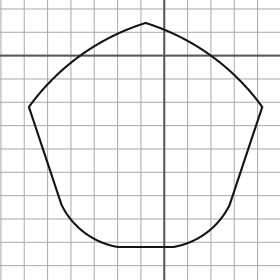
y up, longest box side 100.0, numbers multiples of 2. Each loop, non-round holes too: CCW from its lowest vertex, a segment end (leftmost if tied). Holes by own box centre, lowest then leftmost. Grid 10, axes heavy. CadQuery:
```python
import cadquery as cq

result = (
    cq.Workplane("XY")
    .moveTo(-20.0, -82.0)
    .lineTo(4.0, -82.0)
    .threePointArc((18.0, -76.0), (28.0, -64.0))
    .lineTo(42.0, -22.0)
    .threePointArc((20.0, 0.0), (-8.0, 14.0))
    .threePointArc((-36.0, 0.0), (-58.0, -22.0))
    .lineTo(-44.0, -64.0)
    .threePointArc((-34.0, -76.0), (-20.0, -82.0))
    .close()
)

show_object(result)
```